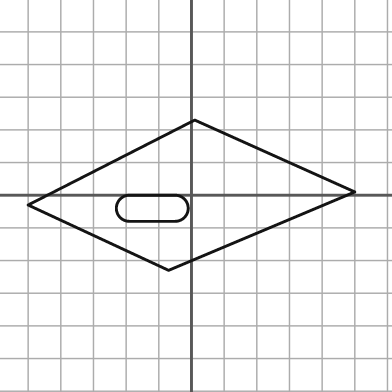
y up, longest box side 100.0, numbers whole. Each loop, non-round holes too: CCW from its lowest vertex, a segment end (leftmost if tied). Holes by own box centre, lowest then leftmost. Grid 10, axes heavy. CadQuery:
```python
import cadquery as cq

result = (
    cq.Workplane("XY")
    .moveTo(-7.0, -23.0)
    .lineTo(50.0, 1.0)
    .lineTo(1.0, 23.0)
    .lineTo(-50.0, -3.0)
    .close()
    .moveTo(-19.0, -8.0)
    .lineTo(-5.0, -8.0)
    .threePointArc((-1.0, -4.0), (-5.0, 0.0))
    .lineTo(-19.0, 0.0)
    .threePointArc((-23.0, -4.0), (-19.0, -8.0))
    .close()
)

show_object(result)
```